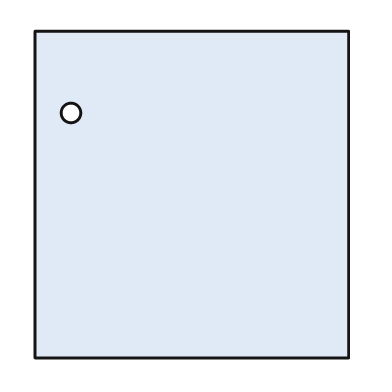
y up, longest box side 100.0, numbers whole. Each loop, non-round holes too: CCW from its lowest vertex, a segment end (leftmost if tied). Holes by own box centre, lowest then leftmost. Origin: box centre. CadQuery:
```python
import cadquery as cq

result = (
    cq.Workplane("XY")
    .moveTo(-48.0, -50.0)
    .lineTo(48.0, -50.0)
    .lineTo(48.0, 50.0)
    .lineTo(-48.0, 50.0)
    .close()
    .moveTo(-37.0, 25.0)
    .circle(3.0)
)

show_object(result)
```